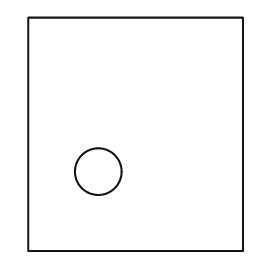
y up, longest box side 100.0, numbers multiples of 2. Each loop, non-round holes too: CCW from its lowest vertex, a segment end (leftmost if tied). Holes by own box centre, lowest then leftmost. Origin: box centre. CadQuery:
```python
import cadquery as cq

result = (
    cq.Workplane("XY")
    .moveTo(-46.0, -50.0)
    .lineTo(46.0, -50.0)
    .lineTo(46.0, 50.0)
    .lineTo(-46.0, 50.0)
    .close()
    .moveTo(-16.0, -16.0)
    .circle(10.0)
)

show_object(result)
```